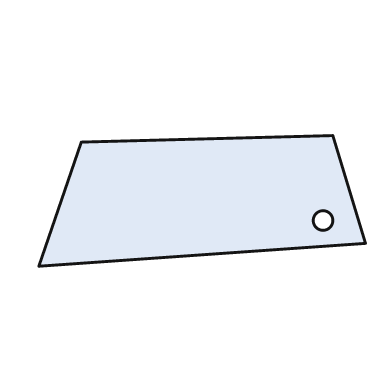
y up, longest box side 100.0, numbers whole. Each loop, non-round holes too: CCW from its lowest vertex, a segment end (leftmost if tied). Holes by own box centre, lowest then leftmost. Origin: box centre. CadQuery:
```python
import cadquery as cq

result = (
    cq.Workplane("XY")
    .moveTo(-50.0, -20.0)
    .lineTo(50.0, -13.0)
    .lineTo(40.0, 20.0)
    .lineTo(-37.0, 18.0)
    .close()
    .moveTo(37.0, -6.0)
    .circle(3.0)
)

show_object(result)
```